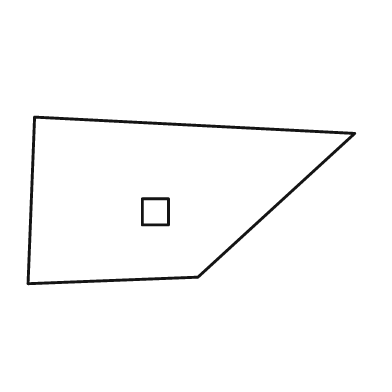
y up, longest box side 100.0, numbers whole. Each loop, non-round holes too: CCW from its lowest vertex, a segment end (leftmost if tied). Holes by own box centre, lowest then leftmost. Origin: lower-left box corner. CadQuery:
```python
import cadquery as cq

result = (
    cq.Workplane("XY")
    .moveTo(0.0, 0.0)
    .lineTo(52.0, 2.0)
    .lineTo(100.0, 46.0)
    .lineTo(2.0, 51.0)
    .close()
    .moveTo(35.0, 18.0)
    .lineTo(43.0, 18.0)
    .lineTo(43.0, 26.0)
    .lineTo(35.0, 26.0)
    .close()
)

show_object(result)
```